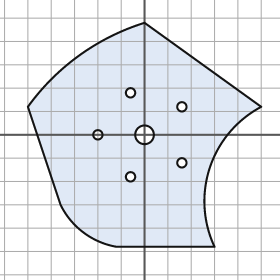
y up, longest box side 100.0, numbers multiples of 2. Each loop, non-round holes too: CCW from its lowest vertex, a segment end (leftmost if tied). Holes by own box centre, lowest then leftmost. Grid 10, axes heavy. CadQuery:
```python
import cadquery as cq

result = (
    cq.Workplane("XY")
    .moveTo(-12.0, -48.0)
    .lineTo(30.0, -48.0)
    .threePointArc((28.0, -14.0), (50.0, 12.0))
    .lineTo(0.0, 48.0)
    .threePointArc((-28.0, 34.0), (-50.0, 12.0))
    .lineTo(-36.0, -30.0)
    .threePointArc((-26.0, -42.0), (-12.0, -48.0))
    .close()
    .moveTo(-6.0, -18.0)
    .circle(2.0)
    .moveTo(16.0, -12.0)
    .circle(2.0)
    .moveTo(-20.0, 0.0)
    .circle(2.0)
    .moveTo(0.0, 0.0)
    .circle(4.0)
    .moveTo(16.0, 12.0)
    .circle(2.0)
    .moveTo(-6.0, 18.0)
    .circle(2.0)
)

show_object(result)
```